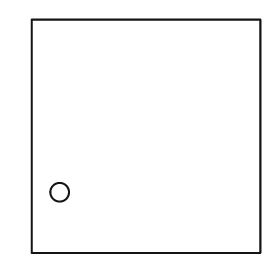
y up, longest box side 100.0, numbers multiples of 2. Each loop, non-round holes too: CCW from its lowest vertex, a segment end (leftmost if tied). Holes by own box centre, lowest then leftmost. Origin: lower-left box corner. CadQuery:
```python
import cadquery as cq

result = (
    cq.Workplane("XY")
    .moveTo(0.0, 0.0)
    .lineTo(98.0, 0.0)
    .lineTo(98.0, 100.0)
    .lineTo(0.0, 100.0)
    .close()
    .moveTo(12.0, 26.0)
    .circle(4.0)
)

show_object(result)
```